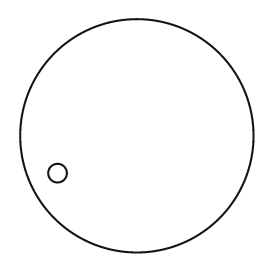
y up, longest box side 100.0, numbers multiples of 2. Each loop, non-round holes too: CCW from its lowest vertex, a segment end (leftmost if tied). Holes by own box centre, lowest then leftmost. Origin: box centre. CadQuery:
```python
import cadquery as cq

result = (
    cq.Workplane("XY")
    .moveTo(0.0, 0.0)
    .circle(50.0)
    .moveTo(-34.0, -16.0)
    .circle(4.0)
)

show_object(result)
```